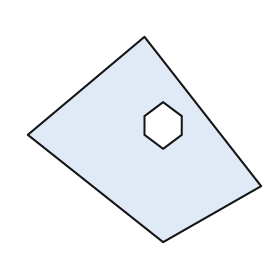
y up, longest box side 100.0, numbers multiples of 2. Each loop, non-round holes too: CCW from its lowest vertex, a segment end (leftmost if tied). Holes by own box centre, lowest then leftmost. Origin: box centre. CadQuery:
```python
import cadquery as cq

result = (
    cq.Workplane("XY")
    .moveTo(8.0, -44.0)
    .lineTo(50.0, -20.0)
    .lineTo(0.0, 44.0)
    .lineTo(-50.0, 2.0)
    .close()
    .moveTo(8.0, -4.0)
    .lineTo(16.0, 2.0)
    .lineTo(16.0, 10.0)
    .lineTo(8.0, 16.0)
    .lineTo(0.0, 10.0)
    .lineTo(0.0, 2.0)
    .close()
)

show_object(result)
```